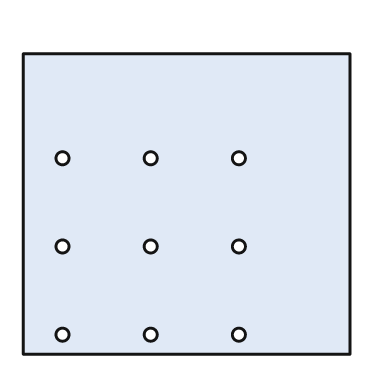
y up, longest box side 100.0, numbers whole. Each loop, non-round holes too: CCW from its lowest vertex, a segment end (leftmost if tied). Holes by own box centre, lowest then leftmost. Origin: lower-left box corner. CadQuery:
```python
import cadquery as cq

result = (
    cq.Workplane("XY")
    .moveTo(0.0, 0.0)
    .lineTo(100.0, 0.0)
    .lineTo(100.0, 92.0)
    .lineTo(0.0, 92.0)
    .close()
    .moveTo(12.0, 6.0)
    .circle(2.0)
    .moveTo(39.0, 6.0)
    .circle(2.0)
    .moveTo(66.0, 6.0)
    .circle(2.0)
    .moveTo(12.0, 33.0)
    .circle(2.0)
    .moveTo(39.0, 33.0)
    .circle(2.0)
    .moveTo(66.0, 33.0)
    .circle(2.0)
    .moveTo(12.0, 60.0)
    .circle(2.0)
    .moveTo(39.0, 60.0)
    .circle(2.0)
    .moveTo(66.0, 60.0)
    .circle(2.0)
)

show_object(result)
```